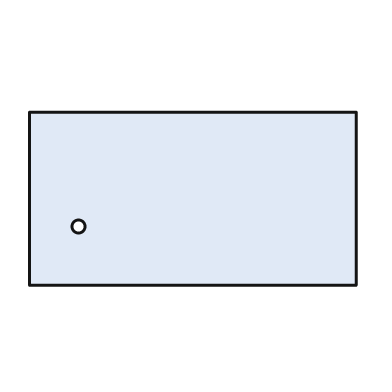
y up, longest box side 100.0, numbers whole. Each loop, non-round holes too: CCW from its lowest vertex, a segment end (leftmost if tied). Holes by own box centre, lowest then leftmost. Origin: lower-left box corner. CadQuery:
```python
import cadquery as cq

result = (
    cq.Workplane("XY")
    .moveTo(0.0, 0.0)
    .lineTo(100.0, 0.0)
    .lineTo(100.0, 53.0)
    .lineTo(0.0, 53.0)
    .close()
    .moveTo(15.0, 18.0)
    .circle(2.0)
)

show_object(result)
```